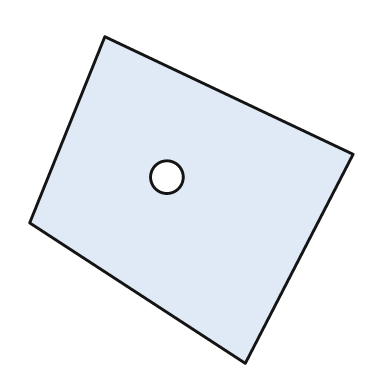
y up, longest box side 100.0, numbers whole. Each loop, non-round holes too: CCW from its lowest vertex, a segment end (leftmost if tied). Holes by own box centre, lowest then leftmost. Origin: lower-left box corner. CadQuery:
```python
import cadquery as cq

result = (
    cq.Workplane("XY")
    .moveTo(66.0, 0.0)
    .lineTo(99.0, 64.0)
    .lineTo(23.0, 100.0)
    .lineTo(0.0, 43.0)
    .close()
    .moveTo(42.0, 57.0)
    .circle(5.0)
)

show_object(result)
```